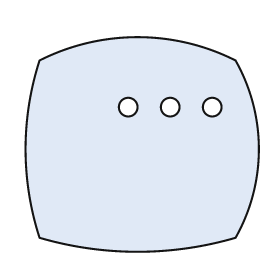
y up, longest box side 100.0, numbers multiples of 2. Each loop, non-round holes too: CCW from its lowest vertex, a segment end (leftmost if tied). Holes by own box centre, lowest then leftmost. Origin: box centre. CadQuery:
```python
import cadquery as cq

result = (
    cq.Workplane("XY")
    .moveTo(-44.0, -40.0)
    .threePointArc((-2.0, -46.0), (40.0, -40.0))
    .threePointArc((50.0, -2.0), (40.0, 36.0))
    .threePointArc((-2.0, 46.0), (-44.0, 36.0))
    .threePointArc((-50.0, -2.0), (-44.0, -40.0))
    .close()
    .moveTo(-6.0, 16.0)
    .circle(4.0)
    .moveTo(12.0, 16.0)
    .circle(4.0)
    .moveTo(30.0, 16.0)
    .circle(4.0)
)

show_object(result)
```